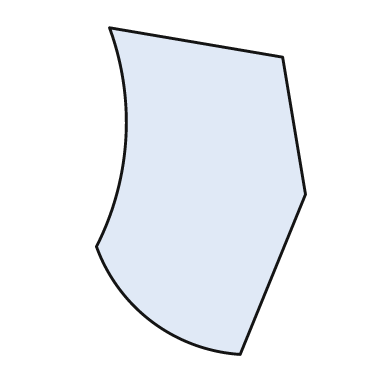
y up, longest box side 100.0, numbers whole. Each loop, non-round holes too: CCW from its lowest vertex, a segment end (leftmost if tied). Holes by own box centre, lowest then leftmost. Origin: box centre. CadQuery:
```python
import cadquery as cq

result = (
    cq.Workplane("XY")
    .moveTo(12.0, -50.0)
    .lineTo(32.0, -1.0)
    .lineTo(25.0, 41.0)
    .lineTo(-28.0, 50.0)
    .threePointArc((-23.0, 16.0), (-32.0, -17.0))
    .threePointArc((-15.0, -40.0), (12.0, -50.0))
    .close()
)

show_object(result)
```